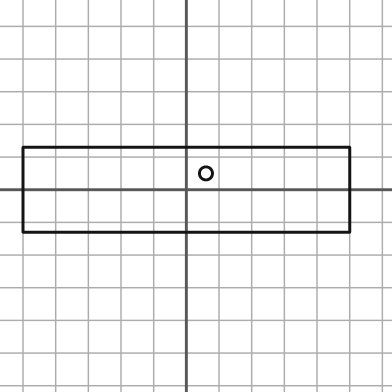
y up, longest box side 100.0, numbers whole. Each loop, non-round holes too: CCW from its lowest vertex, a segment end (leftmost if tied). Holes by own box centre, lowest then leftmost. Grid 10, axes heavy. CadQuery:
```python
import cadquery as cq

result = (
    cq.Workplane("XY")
    .moveTo(-50.0, -13.0)
    .lineTo(50.0, -13.0)
    .lineTo(50.0, 13.0)
    .lineTo(-50.0, 13.0)
    .close()
    .moveTo(6.0, 5.0)
    .circle(2.0)
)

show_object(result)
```